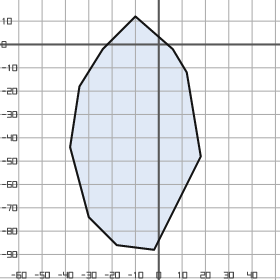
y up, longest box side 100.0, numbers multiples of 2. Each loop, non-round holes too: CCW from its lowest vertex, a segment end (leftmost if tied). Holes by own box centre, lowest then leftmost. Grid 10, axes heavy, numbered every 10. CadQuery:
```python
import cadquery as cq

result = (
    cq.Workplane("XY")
    .moveTo(-2.0, -88.0)
    .lineTo(18.0, -48.0)
    .lineTo(12.0, -12.0)
    .lineTo(6.0, -2.0)
    .lineTo(-10.0, 12.0)
    .lineTo(-24.0, -2.0)
    .lineTo(-34.0, -18.0)
    .lineTo(-38.0, -44.0)
    .lineTo(-30.0, -74.0)
    .lineTo(-18.0, -86.0)
    .close()
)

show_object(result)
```